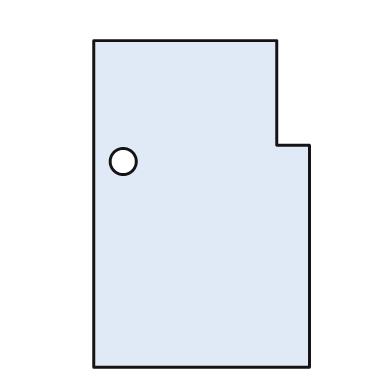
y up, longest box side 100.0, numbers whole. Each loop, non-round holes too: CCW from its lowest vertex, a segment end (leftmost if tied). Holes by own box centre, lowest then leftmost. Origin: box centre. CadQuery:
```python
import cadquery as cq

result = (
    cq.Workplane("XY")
    .moveTo(-33.0, -50.0)
    .lineTo(33.0, -50.0)
    .lineTo(33.0, 18.0)
    .lineTo(23.0, 18.0)
    .lineTo(23.0, 50.0)
    .lineTo(-33.0, 50.0)
    .close()
    .moveTo(-24.0, 13.0)
    .circle(4.0)
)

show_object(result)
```